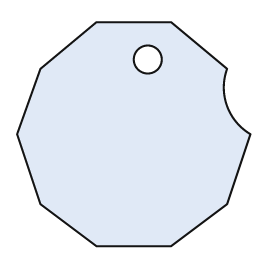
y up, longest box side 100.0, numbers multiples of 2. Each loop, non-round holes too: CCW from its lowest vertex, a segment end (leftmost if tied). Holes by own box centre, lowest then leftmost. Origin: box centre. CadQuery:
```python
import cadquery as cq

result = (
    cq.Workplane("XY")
    .moveTo(-16.0, -48.0)
    .lineTo(16.0, -48.0)
    .lineTo(40.0, -30.0)
    .lineTo(50.0, 0.0)
    .threePointArc((40.0, 12.0), (40.0, 28.0))
    .lineTo(16.0, 48.0)
    .lineTo(-16.0, 48.0)
    .lineTo(-40.0, 28.0)
    .lineTo(-50.0, 0.0)
    .lineTo(-40.0, -30.0)
    .close()
    .moveTo(6.0, 32.0)
    .circle(6.0)
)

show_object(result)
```